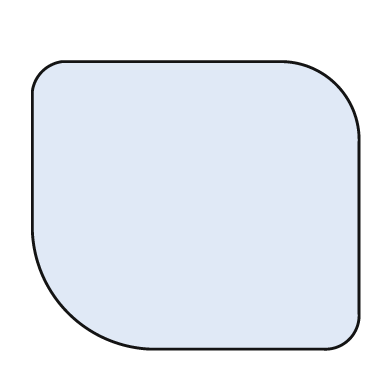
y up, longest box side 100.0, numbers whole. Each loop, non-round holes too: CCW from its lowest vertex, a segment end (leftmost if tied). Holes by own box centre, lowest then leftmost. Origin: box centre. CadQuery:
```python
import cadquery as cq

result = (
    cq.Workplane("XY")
    .moveTo(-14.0, -44.0)
    .lineTo(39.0, -44.0)
    .threePointArc((47.0, -41.0), (50.0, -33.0))
    .lineTo(50.0, 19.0)
    .threePointArc((43.0, 37.0), (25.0, 44.0))
    .lineTo(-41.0, 44.0)
    .threePointArc((-47.0, 41.0), (-50.0, 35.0))
    .lineTo(-50.0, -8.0)
    .threePointArc((-39.0, -33.0), (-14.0, -44.0))
    .close()
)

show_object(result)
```